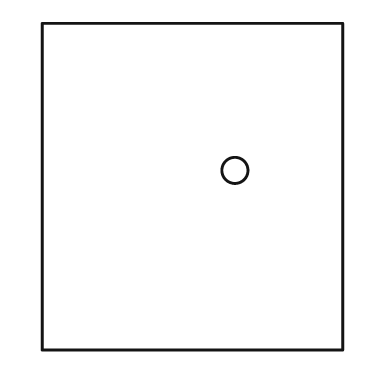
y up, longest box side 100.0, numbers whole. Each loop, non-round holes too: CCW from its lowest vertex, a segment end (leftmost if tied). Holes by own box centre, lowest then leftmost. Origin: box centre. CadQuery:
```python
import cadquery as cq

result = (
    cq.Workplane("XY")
    .moveTo(-46.0, -50.0)
    .lineTo(46.0, -50.0)
    .lineTo(46.0, 50.0)
    .lineTo(-46.0, 50.0)
    .close()
    .moveTo(13.0, 5.0)
    .circle(4.0)
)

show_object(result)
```